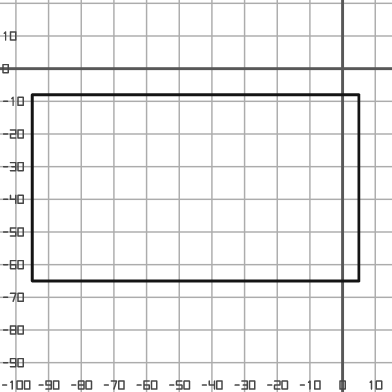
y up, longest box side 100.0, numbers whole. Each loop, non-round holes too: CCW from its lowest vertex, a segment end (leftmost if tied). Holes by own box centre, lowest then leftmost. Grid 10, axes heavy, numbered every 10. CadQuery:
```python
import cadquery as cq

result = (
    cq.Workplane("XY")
    .moveTo(-95.0, -65.0)
    .lineTo(5.0, -65.0)
    .lineTo(5.0, -8.0)
    .lineTo(-95.0, -8.0)
    .close()
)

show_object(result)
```